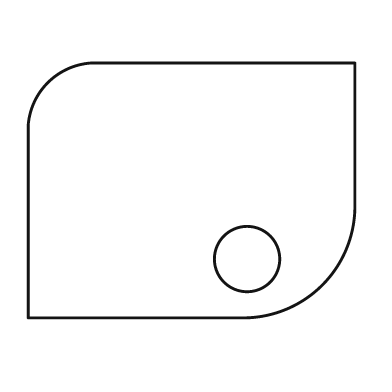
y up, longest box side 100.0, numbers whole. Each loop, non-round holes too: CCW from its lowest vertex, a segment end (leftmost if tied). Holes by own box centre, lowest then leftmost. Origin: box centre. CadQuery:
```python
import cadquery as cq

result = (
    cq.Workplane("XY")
    .moveTo(-50.0, -39.0)
    .lineTo(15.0, -39.0)
    .threePointArc((40.0, -29.0), (50.0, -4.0))
    .lineTo(50.0, 39.0)
    .lineTo(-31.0, 39.0)
    .threePointArc((-44.0, 33.0), (-50.0, 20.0))
    .close()
    .moveTo(17.0, -21.0)
    .circle(10.0)
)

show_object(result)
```